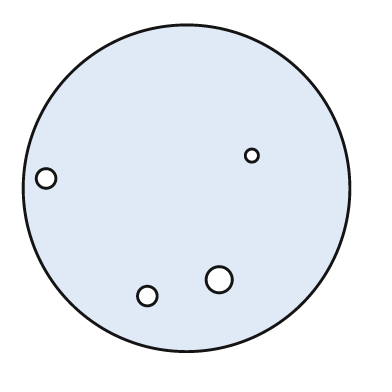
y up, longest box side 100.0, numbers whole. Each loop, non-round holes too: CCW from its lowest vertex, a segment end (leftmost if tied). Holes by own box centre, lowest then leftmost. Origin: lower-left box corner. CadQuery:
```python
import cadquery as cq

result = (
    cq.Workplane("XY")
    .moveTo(50.0, 50.0)
    .circle(50.0)
    .moveTo(38.0, 17.0)
    .circle(3.0)
    .moveTo(60.0, 22.0)
    .circle(4.0)
    .moveTo(7.0, 53.0)
    .circle(3.0)
    .moveTo(70.0, 60.0)
    .circle(2.0)
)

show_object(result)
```